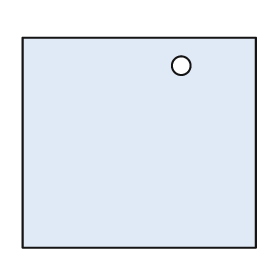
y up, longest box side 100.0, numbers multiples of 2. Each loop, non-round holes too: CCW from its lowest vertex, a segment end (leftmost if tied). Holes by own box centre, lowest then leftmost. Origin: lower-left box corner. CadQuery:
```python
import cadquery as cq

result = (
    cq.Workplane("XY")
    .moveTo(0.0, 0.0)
    .lineTo(100.0, 0.0)
    .lineTo(100.0, 90.0)
    .lineTo(0.0, 90.0)
    .close()
    .moveTo(68.0, 78.0)
    .circle(4.0)
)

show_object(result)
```